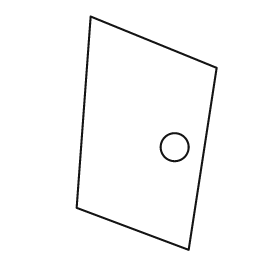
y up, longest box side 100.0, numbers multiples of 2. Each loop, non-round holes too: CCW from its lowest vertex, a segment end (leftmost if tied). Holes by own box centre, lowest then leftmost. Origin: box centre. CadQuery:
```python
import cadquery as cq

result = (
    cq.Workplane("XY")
    .moveTo(18.0, -50.0)
    .lineTo(30.0, 28.0)
    .lineTo(-24.0, 50.0)
    .lineTo(-30.0, -32.0)
    .close()
    .moveTo(12.0, -6.0)
    .circle(6.0)
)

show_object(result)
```